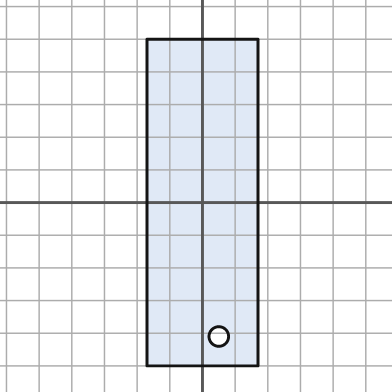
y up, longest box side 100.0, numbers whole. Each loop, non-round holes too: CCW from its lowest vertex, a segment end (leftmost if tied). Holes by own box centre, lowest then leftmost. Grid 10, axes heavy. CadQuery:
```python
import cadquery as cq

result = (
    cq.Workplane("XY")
    .moveTo(-17.0, -50.0)
    .lineTo(17.0, -50.0)
    .lineTo(17.0, 50.0)
    .lineTo(-17.0, 50.0)
    .close()
    .moveTo(5.0, -41.0)
    .circle(3.0)
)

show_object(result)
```